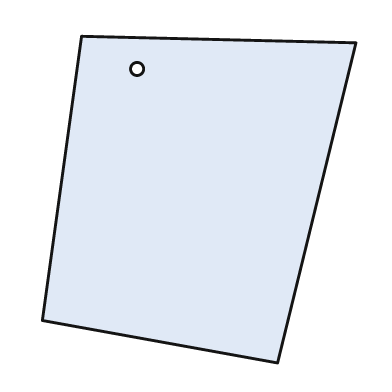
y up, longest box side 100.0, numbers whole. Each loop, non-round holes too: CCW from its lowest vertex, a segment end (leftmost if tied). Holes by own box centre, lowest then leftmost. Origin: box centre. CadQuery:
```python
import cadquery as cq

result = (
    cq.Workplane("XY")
    .moveTo(24.0, -50.0)
    .lineTo(48.0, 48.0)
    .lineTo(-36.0, 50.0)
    .lineTo(-48.0, -37.0)
    .close()
    .moveTo(-19.0, 40.0)
    .circle(2.0)
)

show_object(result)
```